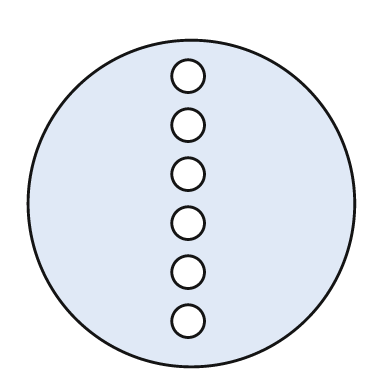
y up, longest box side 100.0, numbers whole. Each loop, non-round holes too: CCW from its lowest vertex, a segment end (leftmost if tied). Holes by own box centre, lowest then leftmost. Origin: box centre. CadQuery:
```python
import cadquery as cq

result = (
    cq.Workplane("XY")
    .moveTo(0.0, 0.0)
    .circle(50.0)
    .moveTo(-1.0, -36.0)
    .circle(5.0)
    .moveTo(-1.0, -21.0)
    .circle(5.0)
    .moveTo(-1.0, -6.0)
    .circle(5.0)
    .moveTo(-1.0, 9.0)
    .circle(5.0)
    .moveTo(-1.0, 24.0)
    .circle(5.0)
    .moveTo(-1.0, 39.0)
    .circle(5.0)
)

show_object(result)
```